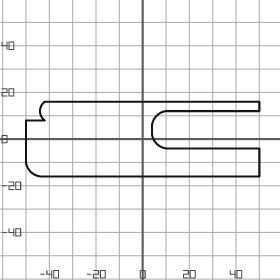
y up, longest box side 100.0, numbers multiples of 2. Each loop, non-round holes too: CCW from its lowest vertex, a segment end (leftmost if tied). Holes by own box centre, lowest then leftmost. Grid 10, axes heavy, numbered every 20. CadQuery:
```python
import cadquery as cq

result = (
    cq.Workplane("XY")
    .moveTo(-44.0, -16.0)
    .lineTo(50.0, -16.0)
    .lineTo(50.0, -4.0)
    .lineTo(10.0, -4.0)
    .threePointArc((6.0, -2.0), (4.0, 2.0))
    .lineTo(4.0, 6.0)
    .threePointArc((6.0, 10.0), (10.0, 12.0))
    .lineTo(50.0, 12.0)
    .lineTo(50.0, 16.0)
    .lineTo(-42.0, 16.0)
    .threePointArc((-44.0, 12.0), (-42.0, 8.0))
    .lineTo(-50.0, 8.0)
    .lineTo(-50.0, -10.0)
    .threePointArc((-48.0, -14.0), (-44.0, -16.0))
    .close()
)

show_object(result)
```